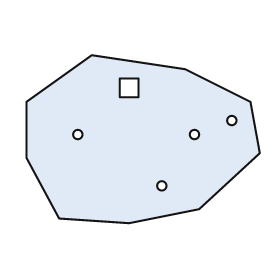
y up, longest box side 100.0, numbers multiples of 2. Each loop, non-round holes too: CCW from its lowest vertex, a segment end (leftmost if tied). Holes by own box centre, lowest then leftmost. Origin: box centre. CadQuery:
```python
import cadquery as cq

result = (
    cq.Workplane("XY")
    .moveTo(-6.0, -36.0)
    .lineTo(24.0, -30.0)
    .lineTo(50.0, -6.0)
    .lineTo(46.0, 16.0)
    .lineTo(18.0, 30.0)
    .lineTo(-22.0, 36.0)
    .lineTo(-50.0, 16.0)
    .lineTo(-50.0, -8.0)
    .lineTo(-36.0, -34.0)
    .close()
    .moveTo(8.0, -20.0)
    .circle(2.0)
    .moveTo(-28.0, 2.0)
    .circle(2.0)
    .moveTo(22.0, 2.0)
    .circle(2.0)
    .moveTo(38.0, 8.0)
    .circle(2.0)
    .moveTo(-10.0, 18.0)
    .lineTo(-2.0, 18.0)
    .lineTo(-2.0, 26.0)
    .lineTo(-10.0, 26.0)
    .close()
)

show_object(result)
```